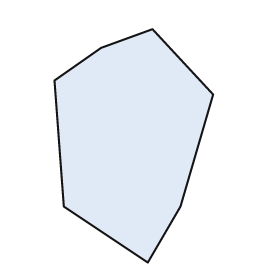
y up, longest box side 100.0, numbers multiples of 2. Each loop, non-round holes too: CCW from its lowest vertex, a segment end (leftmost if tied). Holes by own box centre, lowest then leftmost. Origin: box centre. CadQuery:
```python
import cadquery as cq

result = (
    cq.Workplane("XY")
    .moveTo(6.0, -50.0)
    .lineTo(20.0, -26.0)
    .lineTo(34.0, 22.0)
    .lineTo(8.0, 50.0)
    .lineTo(-14.0, 42.0)
    .lineTo(-34.0, 28.0)
    .lineTo(-30.0, -26.0)
    .close()
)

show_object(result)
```